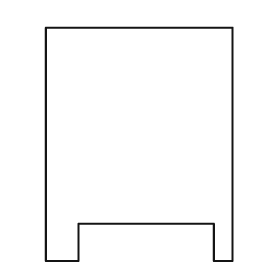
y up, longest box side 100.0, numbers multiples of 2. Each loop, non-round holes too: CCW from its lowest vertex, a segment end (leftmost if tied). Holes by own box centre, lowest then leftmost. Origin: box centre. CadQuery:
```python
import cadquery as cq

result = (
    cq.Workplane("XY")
    .moveTo(-40.0, -50.0)
    .lineTo(-26.0, -50.0)
    .lineTo(-26.0, -34.0)
    .lineTo(32.0, -34.0)
    .lineTo(32.0, -50.0)
    .lineTo(40.0, -50.0)
    .lineTo(40.0, 50.0)
    .lineTo(-40.0, 50.0)
    .close()
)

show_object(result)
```